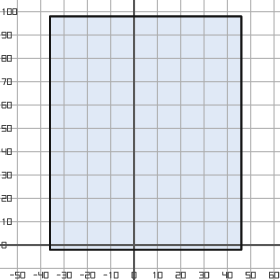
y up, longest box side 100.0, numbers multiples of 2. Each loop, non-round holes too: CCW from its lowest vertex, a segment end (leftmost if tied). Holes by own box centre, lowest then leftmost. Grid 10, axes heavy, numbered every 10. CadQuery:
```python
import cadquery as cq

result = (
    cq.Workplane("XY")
    .moveTo(-36.0, -2.0)
    .lineTo(46.0, -2.0)
    .lineTo(46.0, 98.0)
    .lineTo(-36.0, 98.0)
    .close()
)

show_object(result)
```